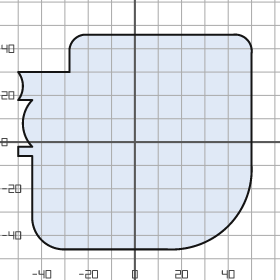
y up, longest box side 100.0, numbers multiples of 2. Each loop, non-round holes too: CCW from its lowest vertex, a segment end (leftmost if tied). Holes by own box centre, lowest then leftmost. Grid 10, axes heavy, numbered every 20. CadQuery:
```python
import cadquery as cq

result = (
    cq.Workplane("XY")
    .moveTo(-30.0, -46.0)
    .lineTo(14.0, -46.0)
    .threePointArc((40.0, -36.0), (50.0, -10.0))
    .lineTo(50.0, 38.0)
    .threePointArc((48.0, 44.0), (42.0, 46.0))
    .lineTo(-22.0, 46.0)
    .threePointArc((-26.0, 44.0), (-28.0, 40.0))
    .lineTo(-28.0, 30.0)
    .lineTo(-50.0, 30.0)
    .threePointArc((-48.0, 24.0), (-50.0, 18.0))
    .lineTo(-44.0, 18.0)
    .threePointArc((-48.0, 8.0), (-44.0, -2.0))
    .lineTo(-50.0, -2.0)
    .lineTo(-50.0, -6.0)
    .lineTo(-44.0, -6.0)
    .lineTo(-44.0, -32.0)
    .threePointArc((-40.0, -42.0), (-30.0, -46.0))
    .close()
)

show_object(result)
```